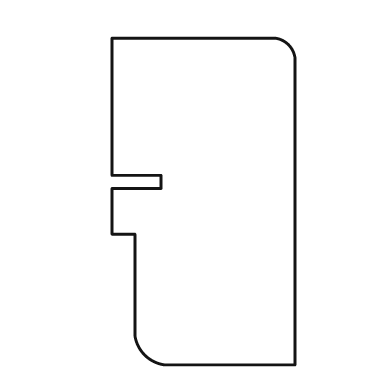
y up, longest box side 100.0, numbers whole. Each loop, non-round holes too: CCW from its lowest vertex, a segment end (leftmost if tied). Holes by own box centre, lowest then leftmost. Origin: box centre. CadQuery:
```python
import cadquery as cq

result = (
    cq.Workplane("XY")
    .moveTo(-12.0, -50.0)
    .lineTo(28.0, -50.0)
    .lineTo(28.0, 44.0)
    .threePointArc((26.0, 48.0), (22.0, 50.0))
    .lineTo(-28.0, 50.0)
    .lineTo(-28.0, 8.0)
    .lineTo(-13.0, 8.0)
    .lineTo(-13.0, 4.0)
    .lineTo(-28.0, 4.0)
    .lineTo(-28.0, -10.0)
    .lineTo(-21.0, -10.0)
    .lineTo(-21.0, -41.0)
    .threePointArc((-18.0, -47.0), (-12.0, -50.0))
    .close()
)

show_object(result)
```